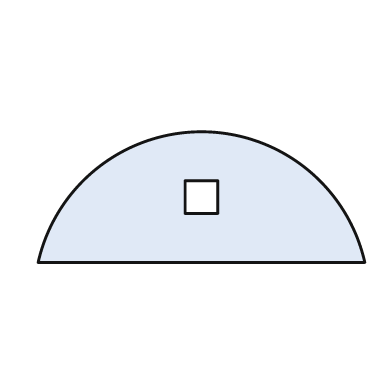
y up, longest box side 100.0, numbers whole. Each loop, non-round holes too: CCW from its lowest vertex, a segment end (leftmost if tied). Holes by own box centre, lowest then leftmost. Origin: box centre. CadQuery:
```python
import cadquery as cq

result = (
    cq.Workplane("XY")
    .moveTo(-50.0, -20.0)
    .lineTo(50.0, -20.0)
    .threePointArc((0.0, 20.0), (-50.0, -20.0))
    .close()
    .moveTo(-5.0, -5.0)
    .lineTo(5.0, -5.0)
    .lineTo(5.0, 5.0)
    .lineTo(-5.0, 5.0)
    .close()
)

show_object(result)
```